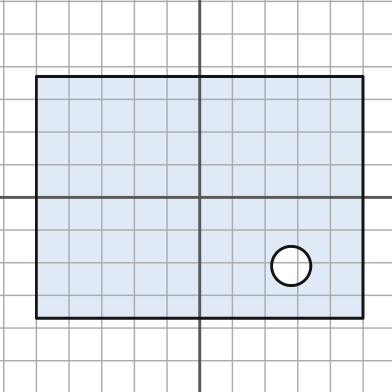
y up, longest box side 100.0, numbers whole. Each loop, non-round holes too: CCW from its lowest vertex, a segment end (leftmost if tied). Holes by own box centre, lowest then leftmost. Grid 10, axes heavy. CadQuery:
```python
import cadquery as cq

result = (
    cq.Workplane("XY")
    .moveTo(-50.0, -37.0)
    .lineTo(50.0, -37.0)
    .lineTo(50.0, 37.0)
    .lineTo(-50.0, 37.0)
    .close()
    .moveTo(28.0, -21.0)
    .circle(6.0)
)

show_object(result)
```